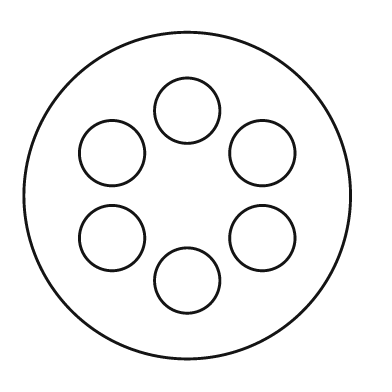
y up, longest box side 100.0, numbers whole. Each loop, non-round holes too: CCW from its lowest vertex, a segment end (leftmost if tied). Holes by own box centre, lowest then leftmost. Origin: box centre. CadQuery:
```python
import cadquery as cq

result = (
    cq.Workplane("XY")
    .moveTo(0.0, 0.0)
    .circle(50.0)
    .moveTo(0.0, -26.0)
    .circle(10.0)
    .moveTo(-23.0, -13.0)
    .circle(10.0)
    .moveTo(23.0, -13.0)
    .circle(10.0)
    .moveTo(-23.0, 13.0)
    .circle(10.0)
    .moveTo(23.0, 13.0)
    .circle(10.0)
    .moveTo(0.0, 26.0)
    .circle(10.0)
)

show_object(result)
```